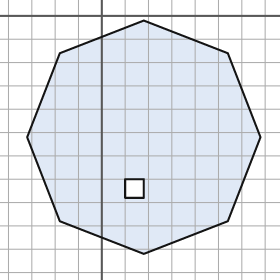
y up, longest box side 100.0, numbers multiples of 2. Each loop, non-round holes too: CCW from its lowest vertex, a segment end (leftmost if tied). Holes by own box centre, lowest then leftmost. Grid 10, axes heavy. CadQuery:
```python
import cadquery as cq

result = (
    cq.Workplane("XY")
    .moveTo(18.0, -102.0)
    .lineTo(54.0, -88.0)
    .lineTo(68.0, -52.0)
    .lineTo(54.0, -16.0)
    .lineTo(18.0, -2.0)
    .lineTo(-18.0, -16.0)
    .lineTo(-32.0, -52.0)
    .lineTo(-18.0, -88.0)
    .close()
    .moveTo(10.0, -78.0)
    .lineTo(18.0, -78.0)
    .lineTo(18.0, -70.0)
    .lineTo(10.0, -70.0)
    .close()
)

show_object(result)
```